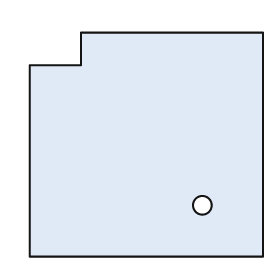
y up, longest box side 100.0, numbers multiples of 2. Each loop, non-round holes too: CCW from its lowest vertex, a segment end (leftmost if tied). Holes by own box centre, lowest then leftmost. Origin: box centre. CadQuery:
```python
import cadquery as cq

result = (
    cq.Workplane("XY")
    .moveTo(-50.0, -48.0)
    .lineTo(50.0, -48.0)
    .lineTo(50.0, 48.0)
    .lineTo(-28.0, 48.0)
    .lineTo(-28.0, 34.0)
    .lineTo(-50.0, 34.0)
    .close()
    .moveTo(24.0, -26.0)
    .circle(4.0)
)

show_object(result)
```